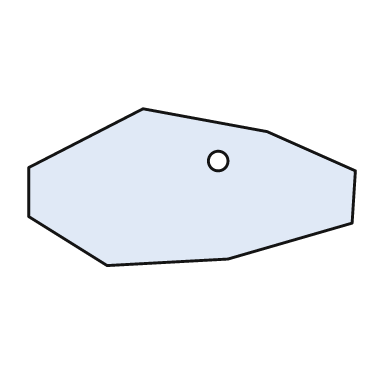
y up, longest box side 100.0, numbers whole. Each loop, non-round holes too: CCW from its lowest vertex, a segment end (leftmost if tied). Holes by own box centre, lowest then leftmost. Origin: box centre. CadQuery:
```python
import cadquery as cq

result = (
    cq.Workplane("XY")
    .moveTo(-26.0, -24.0)
    .lineTo(11.0, -22.0)
    .lineTo(49.0, -11.0)
    .lineTo(50.0, 5.0)
    .lineTo(23.0, 17.0)
    .lineTo(-15.0, 24.0)
    .lineTo(-50.0, 6.0)
    .lineTo(-50.0, -9.0)
    .close()
    .moveTo(8.0, 8.0)
    .circle(3.0)
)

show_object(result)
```